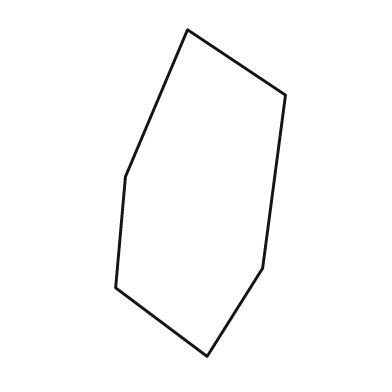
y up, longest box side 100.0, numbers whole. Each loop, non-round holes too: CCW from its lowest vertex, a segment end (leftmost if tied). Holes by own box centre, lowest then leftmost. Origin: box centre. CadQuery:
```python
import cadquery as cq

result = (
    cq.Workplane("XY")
    .moveTo(2.0, -50.0)
    .lineTo(19.0, -23.0)
    .lineTo(26.0, 30.0)
    .lineTo(-4.0, 50.0)
    .lineTo(-23.0, 5.0)
    .lineTo(-26.0, -29.0)
    .close()
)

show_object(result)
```